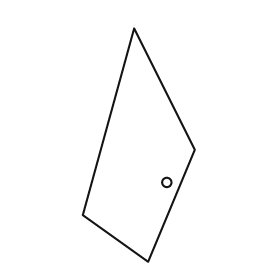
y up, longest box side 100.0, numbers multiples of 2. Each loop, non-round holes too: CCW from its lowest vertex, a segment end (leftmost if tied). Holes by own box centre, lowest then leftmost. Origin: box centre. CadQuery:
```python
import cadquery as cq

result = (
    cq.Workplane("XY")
    .moveTo(4.0, -50.0)
    .lineTo(24.0, -2.0)
    .lineTo(-2.0, 50.0)
    .lineTo(-24.0, -30.0)
    .close()
    .moveTo(12.0, -16.0)
    .circle(2.0)
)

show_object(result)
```